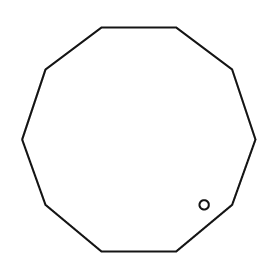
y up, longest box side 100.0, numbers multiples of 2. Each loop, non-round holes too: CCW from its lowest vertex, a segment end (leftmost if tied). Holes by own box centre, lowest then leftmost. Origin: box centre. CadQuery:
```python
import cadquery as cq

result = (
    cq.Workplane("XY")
    .moveTo(-16.0, -48.0)
    .lineTo(16.0, -48.0)
    .lineTo(40.0, -28.0)
    .lineTo(50.0, 0.0)
    .lineTo(40.0, 30.0)
    .lineTo(16.0, 48.0)
    .lineTo(-16.0, 48.0)
    .lineTo(-40.0, 30.0)
    .lineTo(-50.0, 0.0)
    .lineTo(-40.0, -28.0)
    .close()
    .moveTo(28.0, -28.0)
    .circle(2.0)
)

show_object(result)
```